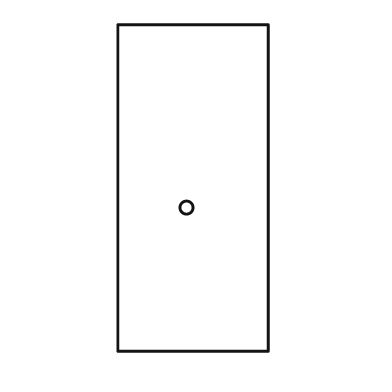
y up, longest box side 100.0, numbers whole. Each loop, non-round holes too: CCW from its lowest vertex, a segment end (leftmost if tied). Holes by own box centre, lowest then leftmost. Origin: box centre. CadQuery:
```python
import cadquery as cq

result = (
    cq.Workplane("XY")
    .moveTo(-23.0, -50.0)
    .lineTo(23.0, -50.0)
    .lineTo(23.0, 50.0)
    .lineTo(-23.0, 50.0)
    .close()
    .moveTo(-2.0, -6.0)
    .circle(2.0)
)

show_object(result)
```